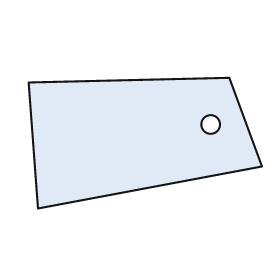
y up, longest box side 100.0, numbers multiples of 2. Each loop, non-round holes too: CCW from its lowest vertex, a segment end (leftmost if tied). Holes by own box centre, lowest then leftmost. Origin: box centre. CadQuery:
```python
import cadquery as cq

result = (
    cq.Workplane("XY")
    .moveTo(-46.0, -28.0)
    .lineTo(50.0, -10.0)
    .lineTo(36.0, 28.0)
    .lineTo(-50.0, 26.0)
    .close()
    .moveTo(28.0, 8.0)
    .circle(4.0)
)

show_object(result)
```